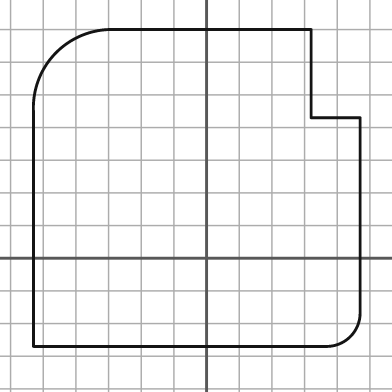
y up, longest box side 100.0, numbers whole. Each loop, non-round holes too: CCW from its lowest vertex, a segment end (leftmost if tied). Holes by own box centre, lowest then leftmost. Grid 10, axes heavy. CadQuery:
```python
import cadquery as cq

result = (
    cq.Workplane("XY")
    .moveTo(-53.0, -27.0)
    .lineTo(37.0, -27.0)
    .threePointArc((44.0, -24.0), (47.0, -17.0))
    .lineTo(47.0, 43.0)
    .lineTo(32.0, 43.0)
    .lineTo(32.0, 70.0)
    .lineTo(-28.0, 70.0)
    .threePointArc((-46.0, 63.0), (-53.0, 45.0))
    .close()
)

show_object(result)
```